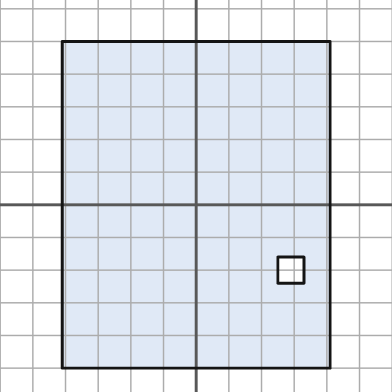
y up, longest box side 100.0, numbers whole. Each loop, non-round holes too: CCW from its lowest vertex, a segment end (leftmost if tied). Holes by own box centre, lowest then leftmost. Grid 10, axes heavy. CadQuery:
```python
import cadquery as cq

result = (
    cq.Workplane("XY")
    .moveTo(-41.0, -50.0)
    .lineTo(41.0, -50.0)
    .lineTo(41.0, 50.0)
    .lineTo(-41.0, 50.0)
    .close()
    .moveTo(25.0, -24.0)
    .lineTo(33.0, -24.0)
    .lineTo(33.0, -16.0)
    .lineTo(25.0, -16.0)
    .close()
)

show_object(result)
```